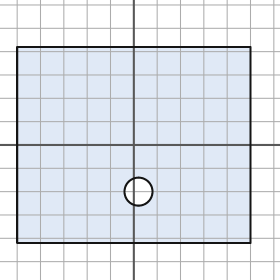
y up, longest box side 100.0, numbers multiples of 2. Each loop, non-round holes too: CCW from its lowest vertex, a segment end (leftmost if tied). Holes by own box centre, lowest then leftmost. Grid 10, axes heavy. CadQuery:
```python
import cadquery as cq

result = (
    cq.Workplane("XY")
    .moveTo(-50.0, -42.0)
    .lineTo(50.0, -42.0)
    .lineTo(50.0, 42.0)
    .lineTo(-50.0, 42.0)
    .close()
    .moveTo(2.0, -20.0)
    .circle(6.0)
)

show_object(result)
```